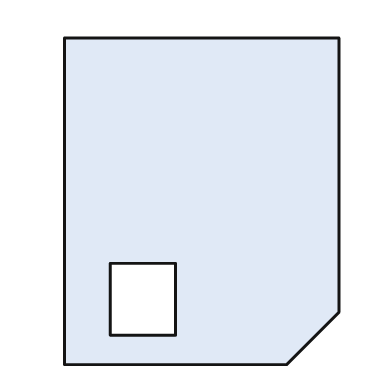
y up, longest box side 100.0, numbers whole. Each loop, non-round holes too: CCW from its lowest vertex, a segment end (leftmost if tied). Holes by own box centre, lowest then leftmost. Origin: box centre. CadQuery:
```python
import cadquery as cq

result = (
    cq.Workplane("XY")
    .moveTo(-42.0, -50.0)
    .lineTo(26.0, -50.0)
    .lineTo(42.0, -34.0)
    .lineTo(42.0, 50.0)
    .lineTo(-42.0, 50.0)
    .close()
    .moveTo(-28.0, -41.0)
    .lineTo(-8.0, -41.0)
    .lineTo(-8.0, -19.0)
    .lineTo(-28.0, -19.0)
    .close()
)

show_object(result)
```